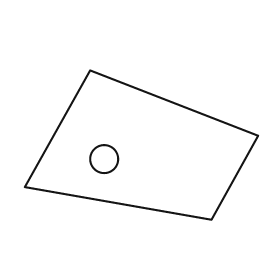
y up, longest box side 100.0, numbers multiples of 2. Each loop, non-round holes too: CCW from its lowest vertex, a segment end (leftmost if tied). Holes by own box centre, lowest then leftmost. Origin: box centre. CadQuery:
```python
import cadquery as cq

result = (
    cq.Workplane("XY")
    .moveTo(30.0, -32.0)
    .lineTo(50.0, 4.0)
    .lineTo(-22.0, 32.0)
    .lineTo(-50.0, -18.0)
    .close()
    .moveTo(-16.0, -6.0)
    .circle(6.0)
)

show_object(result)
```